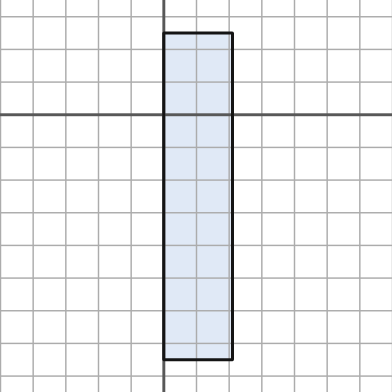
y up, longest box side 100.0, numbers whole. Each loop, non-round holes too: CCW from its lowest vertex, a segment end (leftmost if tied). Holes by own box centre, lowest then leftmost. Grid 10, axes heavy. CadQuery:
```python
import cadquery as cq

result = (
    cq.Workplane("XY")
    .moveTo(0.0, -75.0)
    .lineTo(21.0, -75.0)
    .lineTo(21.0, 25.0)
    .lineTo(0.0, 25.0)
    .close()
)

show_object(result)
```